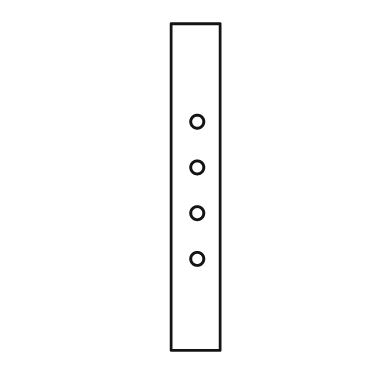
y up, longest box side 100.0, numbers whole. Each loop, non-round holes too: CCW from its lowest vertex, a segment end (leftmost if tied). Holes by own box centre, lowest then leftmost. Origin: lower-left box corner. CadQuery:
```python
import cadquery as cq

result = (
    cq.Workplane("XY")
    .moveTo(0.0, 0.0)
    .lineTo(15.0, 0.0)
    .lineTo(15.0, 100.0)
    .lineTo(0.0, 100.0)
    .close()
    .moveTo(8.0, 28.0)
    .circle(2.0)
    .moveTo(8.0, 42.0)
    .circle(2.0)
    .moveTo(8.0, 56.0)
    .circle(2.0)
    .moveTo(8.0, 70.0)
    .circle(2.0)
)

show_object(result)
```